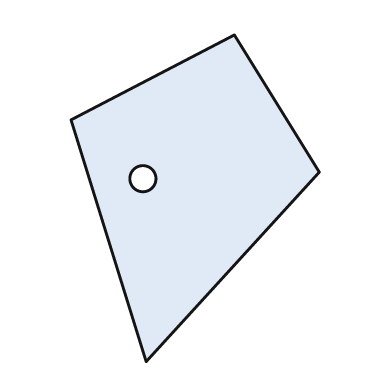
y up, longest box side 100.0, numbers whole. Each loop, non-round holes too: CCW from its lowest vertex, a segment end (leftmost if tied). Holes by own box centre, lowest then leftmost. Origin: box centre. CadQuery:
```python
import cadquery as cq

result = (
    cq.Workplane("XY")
    .moveTo(-15.0, -50.0)
    .lineTo(38.0, 8.0)
    .lineTo(12.0, 50.0)
    .lineTo(-38.0, 24.0)
    .close()
    .moveTo(-16.0, 6.0)
    .circle(4.0)
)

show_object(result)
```